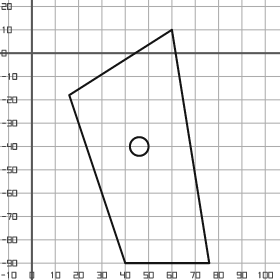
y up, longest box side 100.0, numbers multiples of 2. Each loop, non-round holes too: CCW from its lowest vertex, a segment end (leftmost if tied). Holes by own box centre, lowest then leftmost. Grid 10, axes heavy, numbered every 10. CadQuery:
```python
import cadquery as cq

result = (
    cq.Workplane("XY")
    .moveTo(40.0, -90.0)
    .lineTo(76.0, -90.0)
    .lineTo(60.0, 10.0)
    .lineTo(16.0, -18.0)
    .close()
    .moveTo(46.0, -40.0)
    .circle(4.0)
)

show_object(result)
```